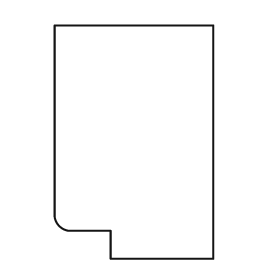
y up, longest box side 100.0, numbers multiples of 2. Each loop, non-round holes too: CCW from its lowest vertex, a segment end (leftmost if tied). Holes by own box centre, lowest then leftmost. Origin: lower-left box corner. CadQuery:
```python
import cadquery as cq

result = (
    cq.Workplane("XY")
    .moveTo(24.0, 0.0)
    .lineTo(68.0, 0.0)
    .lineTo(68.0, 100.0)
    .lineTo(0.0, 100.0)
    .lineTo(0.0, 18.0)
    .threePointArc((2.0, 14.0), (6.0, 12.0))
    .lineTo(24.0, 12.0)
    .close()
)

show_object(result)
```